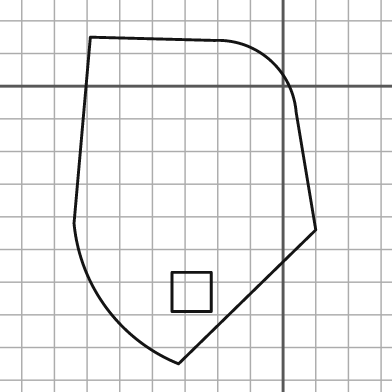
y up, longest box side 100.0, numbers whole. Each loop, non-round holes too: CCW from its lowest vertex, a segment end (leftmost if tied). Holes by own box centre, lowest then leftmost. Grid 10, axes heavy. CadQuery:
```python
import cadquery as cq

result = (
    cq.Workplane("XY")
    .moveTo(-32.0, -85.0)
    .lineTo(10.0, -44.0)
    .lineTo(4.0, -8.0)
    .threePointArc((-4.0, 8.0), (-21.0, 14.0))
    .lineTo(-59.0, 15.0)
    .lineTo(-64.0, -42.0)
    .threePointArc((-54.0, -68.0), (-32.0, -85.0))
    .close()
    .moveTo(-34.0, -69.0)
    .lineTo(-22.0, -69.0)
    .lineTo(-22.0, -57.0)
    .lineTo(-34.0, -57.0)
    .close()
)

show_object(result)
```